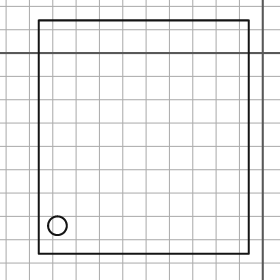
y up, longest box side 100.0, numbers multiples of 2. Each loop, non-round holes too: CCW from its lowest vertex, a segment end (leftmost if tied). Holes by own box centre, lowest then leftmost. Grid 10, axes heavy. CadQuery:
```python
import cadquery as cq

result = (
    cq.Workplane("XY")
    .moveTo(-96.0, -86.0)
    .lineTo(-6.0, -86.0)
    .lineTo(-6.0, 14.0)
    .lineTo(-96.0, 14.0)
    .close()
    .moveTo(-88.0, -74.0)
    .circle(4.0)
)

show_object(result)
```